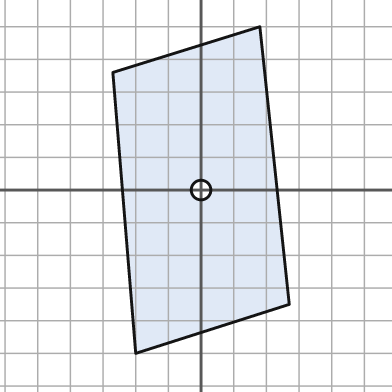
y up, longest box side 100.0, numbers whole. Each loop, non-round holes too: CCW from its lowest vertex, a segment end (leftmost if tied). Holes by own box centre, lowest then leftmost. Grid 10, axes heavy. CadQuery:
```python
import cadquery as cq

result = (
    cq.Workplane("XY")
    .moveTo(-20.0, -50.0)
    .lineTo(27.0, -35.0)
    .lineTo(18.0, 50.0)
    .lineTo(-27.0, 36.0)
    .close()
    .moveTo(0.0, 0.0)
    .circle(3.0)
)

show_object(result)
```